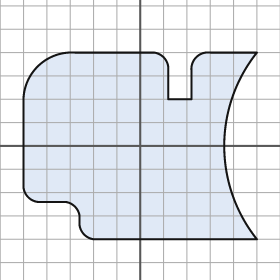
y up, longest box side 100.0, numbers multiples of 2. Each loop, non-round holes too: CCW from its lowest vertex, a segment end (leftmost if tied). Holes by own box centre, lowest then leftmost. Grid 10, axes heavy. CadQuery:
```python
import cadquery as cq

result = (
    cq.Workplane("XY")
    .moveTo(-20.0, -40.0)
    .lineTo(50.0, -40.0)
    .threePointArc((36.0, 0.0), (50.0, 40.0))
    .lineTo(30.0, 40.0)
    .threePointArc((24.0, 38.0), (22.0, 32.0))
    .lineTo(22.0, 20.0)
    .lineTo(12.0, 20.0)
    .lineTo(12.0, 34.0)
    .threePointArc((10.0, 38.0), (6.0, 40.0))
    .lineTo(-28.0, 40.0)
    .threePointArc((-44.0, 34.0), (-50.0, 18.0))
    .lineTo(-50.0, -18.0)
    .threePointArc((-48.0, -22.0), (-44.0, -24.0))
    .lineTo(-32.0, -24.0)
    .threePointArc((-28.0, -26.0), (-26.0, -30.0))
    .lineTo(-26.0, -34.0)
    .threePointArc((-24.0, -38.0), (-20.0, -40.0))
    .close()
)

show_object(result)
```